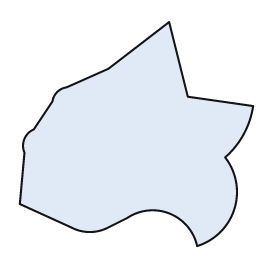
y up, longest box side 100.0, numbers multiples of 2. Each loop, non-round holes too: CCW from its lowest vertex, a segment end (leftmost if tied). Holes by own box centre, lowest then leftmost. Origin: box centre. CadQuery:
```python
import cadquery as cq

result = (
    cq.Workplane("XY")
    .moveTo(26.0, -48.0)
    .threePointArc((42.0, -32.0), (38.0, -10.0))
    .threePointArc((46.0, 0.0), (50.0, 12.0))
    .lineTo(22.0, 16.0)
    .lineTo(14.0, 48.0)
    .lineTo(-12.0, 28.0)
    .lineTo(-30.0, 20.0)
    .threePointArc((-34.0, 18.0), (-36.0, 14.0))
    .lineTo(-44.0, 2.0)
    .threePointArc((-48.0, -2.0), (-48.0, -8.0))
    .lineTo(-50.0, -30.0)
    .lineTo(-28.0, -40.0)
    .threePointArc((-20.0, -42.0), (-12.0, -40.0))
    .lineTo(-4.0, -36.0)
    .threePointArc((14.0, -34.0), (26.0, -48.0))
    .close()
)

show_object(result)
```